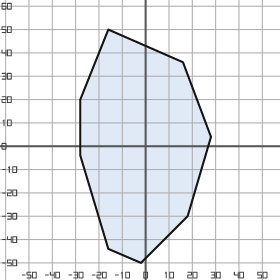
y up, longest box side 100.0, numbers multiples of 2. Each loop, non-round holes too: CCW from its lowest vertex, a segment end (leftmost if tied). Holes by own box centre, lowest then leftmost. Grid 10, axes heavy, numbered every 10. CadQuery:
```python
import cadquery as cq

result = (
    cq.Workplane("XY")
    .moveTo(-2.0, -50.0)
    .lineTo(18.0, -30.0)
    .lineTo(28.0, 4.0)
    .lineTo(16.0, 36.0)
    .lineTo(-16.0, 50.0)
    .lineTo(-28.0, 20.0)
    .lineTo(-28.0, -4.0)
    .lineTo(-16.0, -44.0)
    .close()
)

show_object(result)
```